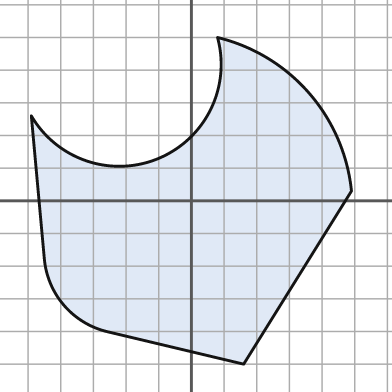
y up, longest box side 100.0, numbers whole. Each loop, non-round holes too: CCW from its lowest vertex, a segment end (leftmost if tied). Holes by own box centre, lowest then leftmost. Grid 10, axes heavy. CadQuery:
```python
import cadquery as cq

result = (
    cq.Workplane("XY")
    .moveTo(16.0, -50.0)
    .lineTo(49.0, 3.0)
    .threePointArc((36.0, 33.0), (8.0, 50.0))
    .threePointArc((-10.0, 13.0), (-49.0, 26.0))
    .lineTo(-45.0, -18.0)
    .threePointArc((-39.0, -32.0), (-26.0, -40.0))
    .close()
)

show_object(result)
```